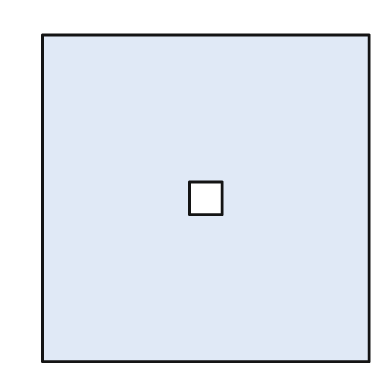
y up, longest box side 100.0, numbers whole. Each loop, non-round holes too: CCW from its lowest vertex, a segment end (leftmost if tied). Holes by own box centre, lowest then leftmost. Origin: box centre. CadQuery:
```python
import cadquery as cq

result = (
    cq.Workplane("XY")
    .moveTo(-50.0, -50.0)
    .lineTo(50.0, -50.0)
    .lineTo(50.0, 50.0)
    .lineTo(-50.0, 50.0)
    .close()
    .moveTo(-5.0, -5.0)
    .lineTo(5.0, -5.0)
    .lineTo(5.0, 5.0)
    .lineTo(-5.0, 5.0)
    .close()
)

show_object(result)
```